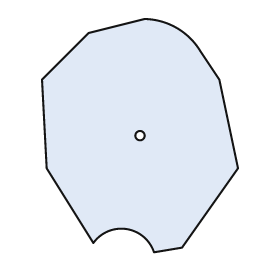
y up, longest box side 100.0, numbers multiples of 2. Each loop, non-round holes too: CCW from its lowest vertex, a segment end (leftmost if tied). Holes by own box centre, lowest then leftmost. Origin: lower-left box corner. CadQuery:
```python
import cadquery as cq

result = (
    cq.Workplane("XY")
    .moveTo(48.0, 0.0)
    .lineTo(60.0, 2.0)
    .lineTo(84.0, 36.0)
    .lineTo(76.0, 74.0)
    .lineTo(68.0, 86.0)
    .threePointArc((58.0, 96.0), (44.0, 100.0))
    .lineTo(20.0, 94.0)
    .lineTo(0.0, 74.0)
    .lineTo(2.0, 36.0)
    .lineTo(22.0, 4.0)
    .threePointArc((36.0, 10.0), (48.0, 0.0))
    .close()
    .moveTo(42.0, 50.0)
    .circle(2.0)
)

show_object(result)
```